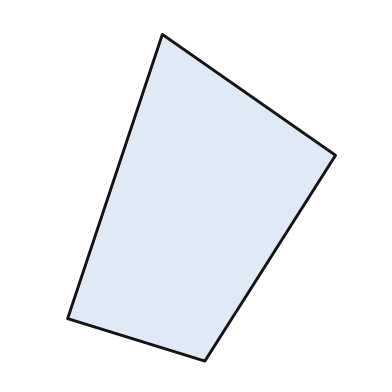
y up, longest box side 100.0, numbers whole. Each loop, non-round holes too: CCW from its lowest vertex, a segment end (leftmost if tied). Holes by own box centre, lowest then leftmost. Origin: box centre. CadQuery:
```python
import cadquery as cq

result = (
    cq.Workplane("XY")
    .moveTo(1.0, -50.0)
    .lineTo(41.0, 13.0)
    .lineTo(-12.0, 50.0)
    .lineTo(-41.0, -37.0)
    .close()
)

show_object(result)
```